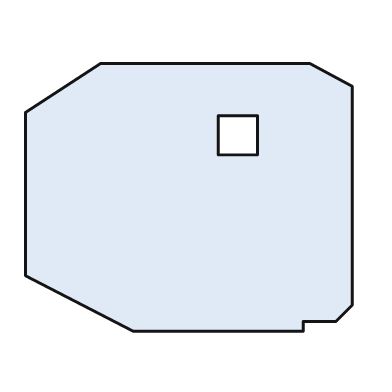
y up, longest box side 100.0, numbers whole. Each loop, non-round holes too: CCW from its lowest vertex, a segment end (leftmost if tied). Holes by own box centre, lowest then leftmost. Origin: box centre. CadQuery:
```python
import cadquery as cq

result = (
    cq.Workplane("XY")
    .moveTo(-17.0, -41.0)
    .lineTo(35.0, -41.0)
    .lineTo(35.0, -38.0)
    .lineTo(45.0, -38.0)
    .lineTo(50.0, -33.0)
    .lineTo(50.0, 34.0)
    .lineTo(37.0, 41.0)
    .lineTo(-27.0, 41.0)
    .lineTo(-50.0, 26.0)
    .lineTo(-50.0, -24.0)
    .close()
    .moveTo(9.0, 13.0)
    .lineTo(21.0, 13.0)
    .lineTo(21.0, 25.0)
    .lineTo(9.0, 25.0)
    .close()
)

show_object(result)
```